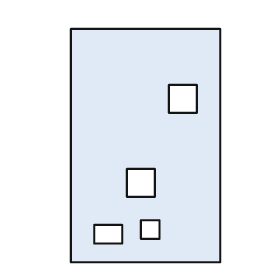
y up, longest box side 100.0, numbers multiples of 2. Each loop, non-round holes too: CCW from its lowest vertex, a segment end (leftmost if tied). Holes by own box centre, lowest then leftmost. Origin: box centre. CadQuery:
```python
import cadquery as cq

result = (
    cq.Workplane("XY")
    .moveTo(-32.0, -50.0)
    .lineTo(32.0, -50.0)
    .lineTo(32.0, 50.0)
    .lineTo(-32.0, 50.0)
    .close()
    .moveTo(-22.0, -42.0)
    .lineTo(-10.0, -42.0)
    .lineTo(-10.0, -34.0)
    .lineTo(-22.0, -34.0)
    .close()
    .moveTo(-2.0, -40.0)
    .lineTo(6.0, -40.0)
    .lineTo(6.0, -32.0)
    .lineTo(-2.0, -32.0)
    .close()
    .moveTo(-8.0, -22.0)
    .lineTo(4.0, -22.0)
    .lineTo(4.0, -10.0)
    .lineTo(-8.0, -10.0)
    .close()
    .moveTo(10.0, 14.0)
    .lineTo(22.0, 14.0)
    .lineTo(22.0, 26.0)
    .lineTo(10.0, 26.0)
    .close()
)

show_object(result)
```